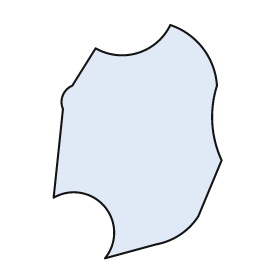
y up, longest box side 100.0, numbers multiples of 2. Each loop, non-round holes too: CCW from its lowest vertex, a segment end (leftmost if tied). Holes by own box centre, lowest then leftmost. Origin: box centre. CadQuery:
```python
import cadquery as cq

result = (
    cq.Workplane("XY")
    .moveTo(-14.0, -50.0)
    .lineTo(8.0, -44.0)
    .threePointArc((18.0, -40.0), (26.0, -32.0))
    .lineTo(36.0, -8.0)
    .threePointArc((32.0, 8.0), (34.0, 24.0))
    .threePointArc((28.0, 40.0), (14.0, 50.0))
    .threePointArc((0.0, 38.0), (-18.0, 40.0))
    .lineTo(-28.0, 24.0)
    .threePointArc((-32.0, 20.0), (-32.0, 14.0))
    .lineTo(-36.0, -24.0)
    .threePointArc((-14.0, -28.0), (-14.0, -50.0))
    .close()
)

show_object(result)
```